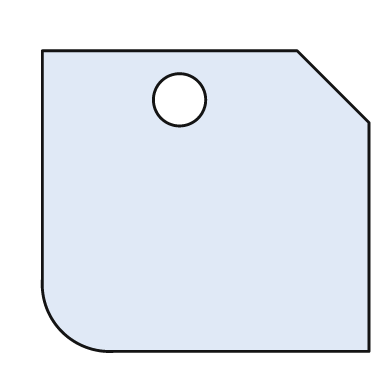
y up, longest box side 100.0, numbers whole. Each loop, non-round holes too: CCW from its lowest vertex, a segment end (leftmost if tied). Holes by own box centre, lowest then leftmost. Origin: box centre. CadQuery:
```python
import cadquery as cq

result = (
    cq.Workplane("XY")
    .moveTo(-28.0, -46.0)
    .lineTo(50.0, -46.0)
    .lineTo(50.0, 24.0)
    .lineTo(28.0, 46.0)
    .lineTo(-50.0, 46.0)
    .lineTo(-50.0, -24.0)
    .threePointArc((-44.0, -40.0), (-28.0, -46.0))
    .close()
    .moveTo(-8.0, 31.0)
    .circle(8.0)
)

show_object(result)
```